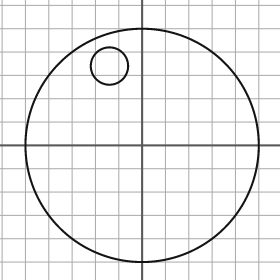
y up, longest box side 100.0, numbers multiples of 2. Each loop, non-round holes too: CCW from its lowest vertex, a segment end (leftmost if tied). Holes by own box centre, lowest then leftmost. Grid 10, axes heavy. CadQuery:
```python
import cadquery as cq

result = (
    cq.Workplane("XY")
    .moveTo(0.0, 0.0)
    .circle(50.0)
    .moveTo(-14.0, 34.0)
    .circle(8.0)
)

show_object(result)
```